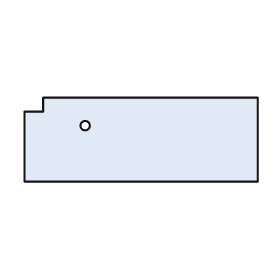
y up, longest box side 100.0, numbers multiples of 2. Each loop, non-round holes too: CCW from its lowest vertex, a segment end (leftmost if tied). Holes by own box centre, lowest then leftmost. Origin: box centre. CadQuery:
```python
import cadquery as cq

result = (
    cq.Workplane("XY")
    .moveTo(-50.0, -18.0)
    .lineTo(50.0, -18.0)
    .lineTo(50.0, 18.0)
    .lineTo(-42.0, 18.0)
    .lineTo(-42.0, 12.0)
    .lineTo(-50.0, 12.0)
    .close()
    .moveTo(-24.0, 6.0)
    .circle(2.0)
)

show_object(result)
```